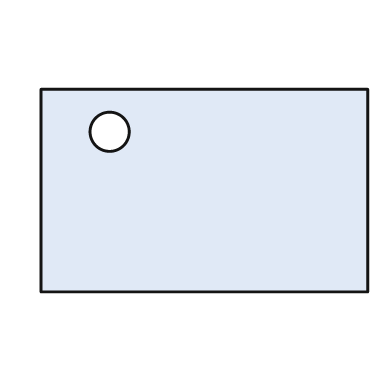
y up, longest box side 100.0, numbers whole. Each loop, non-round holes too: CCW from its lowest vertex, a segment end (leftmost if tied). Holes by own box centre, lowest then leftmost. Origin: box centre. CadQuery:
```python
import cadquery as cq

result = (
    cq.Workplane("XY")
    .moveTo(-50.0, -31.0)
    .lineTo(50.0, -31.0)
    .lineTo(50.0, 31.0)
    .lineTo(-50.0, 31.0)
    .close()
    .moveTo(-29.0, 18.0)
    .circle(6.0)
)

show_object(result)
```